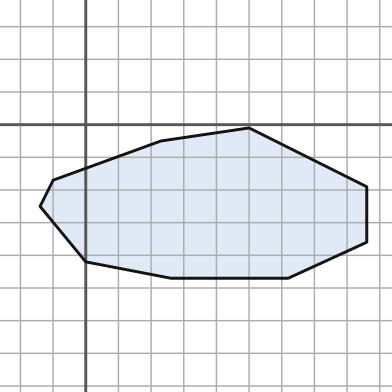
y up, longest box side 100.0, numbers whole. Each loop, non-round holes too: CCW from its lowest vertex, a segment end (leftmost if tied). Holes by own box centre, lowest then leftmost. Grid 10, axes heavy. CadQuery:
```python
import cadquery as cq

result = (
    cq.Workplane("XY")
    .moveTo(26.0, -47.0)
    .lineTo(62.0, -47.0)
    .lineTo(86.0, -36.0)
    .lineTo(86.0, -19.0)
    .lineTo(50.0, -1.0)
    .lineTo(23.0, -5.0)
    .lineTo(-10.0, -17.0)
    .lineTo(-14.0, -25.0)
    .lineTo(0.0, -42.0)
    .close()
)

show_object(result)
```